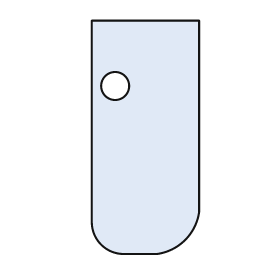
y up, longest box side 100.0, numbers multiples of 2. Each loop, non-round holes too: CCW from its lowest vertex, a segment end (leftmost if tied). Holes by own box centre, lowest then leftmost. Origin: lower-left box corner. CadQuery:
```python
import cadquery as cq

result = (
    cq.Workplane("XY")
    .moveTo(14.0, 0.0)
    .lineTo(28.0, 0.0)
    .threePointArc((40.0, 6.0), (46.0, 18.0))
    .lineTo(46.0, 100.0)
    .lineTo(0.0, 100.0)
    .lineTo(0.0, 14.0)
    .threePointArc((4.0, 4.0), (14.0, 0.0))
    .close()
    .moveTo(10.0, 72.0)
    .circle(6.0)
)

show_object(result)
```